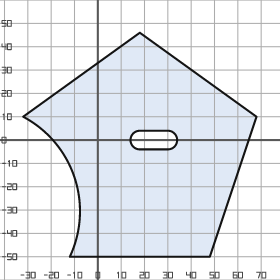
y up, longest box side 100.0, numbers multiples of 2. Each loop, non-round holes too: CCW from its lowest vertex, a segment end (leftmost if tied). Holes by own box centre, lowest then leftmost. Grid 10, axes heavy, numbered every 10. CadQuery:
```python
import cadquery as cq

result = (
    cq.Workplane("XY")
    .moveTo(-12.0, -50.0)
    .lineTo(48.0, -50.0)
    .lineTo(68.0, 10.0)
    .lineTo(18.0, 46.0)
    .lineTo(-32.0, 10.0)
    .threePointArc((-10.0, -16.0), (-12.0, -50.0))
    .close()
    .moveTo(18.0, -4.0)
    .lineTo(30.0, -4.0)
    .threePointArc((34.0, 0.0), (30.0, 4.0))
    .lineTo(18.0, 4.0)
    .threePointArc((14.0, 0.0), (18.0, -4.0))
    .close()
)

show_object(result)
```